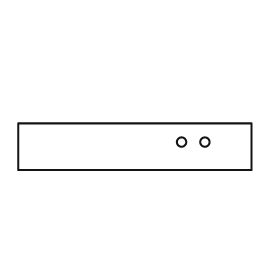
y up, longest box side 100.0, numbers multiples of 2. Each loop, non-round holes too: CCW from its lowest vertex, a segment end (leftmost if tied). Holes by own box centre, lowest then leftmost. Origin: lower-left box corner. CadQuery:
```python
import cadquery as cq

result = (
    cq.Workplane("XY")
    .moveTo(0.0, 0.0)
    .lineTo(100.0, 0.0)
    .lineTo(100.0, 20.0)
    .lineTo(0.0, 20.0)
    .close()
    .moveTo(70.0, 12.0)
    .circle(2.0)
    .moveTo(80.0, 12.0)
    .circle(2.0)
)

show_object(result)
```